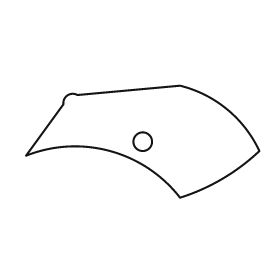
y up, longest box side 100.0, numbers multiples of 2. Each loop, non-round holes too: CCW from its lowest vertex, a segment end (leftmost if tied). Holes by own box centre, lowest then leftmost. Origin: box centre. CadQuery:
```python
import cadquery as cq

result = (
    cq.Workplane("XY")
    .moveTo(16.0, -24.0)
    .threePointArc((34.0, -16.0), (50.0, -4.0))
    .threePointArc((36.0, 14.0), (16.0, 24.0))
    .lineTo(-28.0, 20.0)
    .threePointArc((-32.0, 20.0), (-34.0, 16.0))
    .lineTo(-50.0, -6.0)
    .threePointArc((-14.0, -4.0), (16.0, -24.0))
    .close()
    .moveTo(0.0, 0.0)
    .circle(4.0)
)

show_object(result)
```